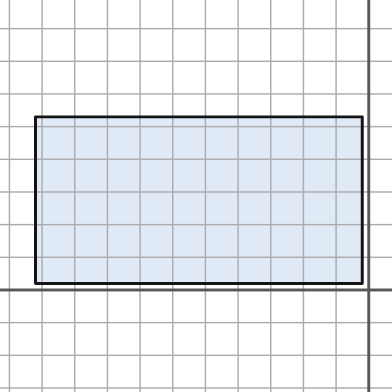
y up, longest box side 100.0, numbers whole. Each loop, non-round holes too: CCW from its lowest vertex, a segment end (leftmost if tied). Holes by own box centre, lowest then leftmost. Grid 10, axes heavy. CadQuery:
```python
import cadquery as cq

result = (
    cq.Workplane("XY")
    .moveTo(-102.0, 2.0)
    .lineTo(-2.0, 2.0)
    .lineTo(-2.0, 53.0)
    .lineTo(-102.0, 53.0)
    .close()
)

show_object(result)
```